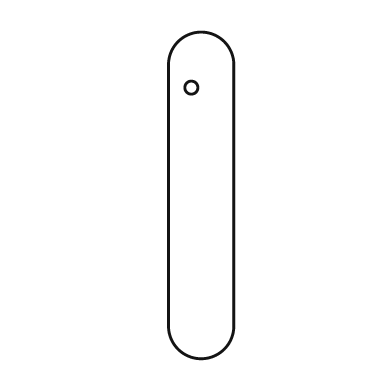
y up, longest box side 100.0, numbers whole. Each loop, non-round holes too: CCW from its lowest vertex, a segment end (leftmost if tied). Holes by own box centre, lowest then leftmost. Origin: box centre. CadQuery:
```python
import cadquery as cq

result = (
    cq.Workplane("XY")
    .moveTo(-10.0, -40.0)
    .threePointArc((0.0, -50.0), (10.0, -40.0))
    .lineTo(10.0, 40.0)
    .threePointArc((0.0, 50.0), (-10.0, 40.0))
    .close()
    .moveTo(-3.0, 33.0)
    .circle(2.0)
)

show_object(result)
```